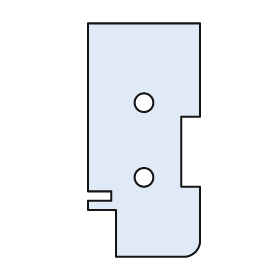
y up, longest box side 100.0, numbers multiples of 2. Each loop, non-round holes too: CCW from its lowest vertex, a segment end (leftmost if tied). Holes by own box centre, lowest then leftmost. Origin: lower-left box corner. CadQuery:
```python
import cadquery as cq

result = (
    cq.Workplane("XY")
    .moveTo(12.0, 0.0)
    .lineTo(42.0, 0.0)
    .threePointArc((46.0, 2.0), (48.0, 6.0))
    .lineTo(48.0, 30.0)
    .lineTo(40.0, 30.0)
    .lineTo(40.0, 60.0)
    .lineTo(48.0, 60.0)
    .lineTo(48.0, 100.0)
    .lineTo(0.0, 100.0)
    .lineTo(0.0, 28.0)
    .lineTo(10.0, 28.0)
    .lineTo(10.0, 24.0)
    .lineTo(0.0, 24.0)
    .lineTo(0.0, 20.0)
    .lineTo(12.0, 20.0)
    .close()
    .moveTo(24.0, 34.0)
    .circle(4.0)
    .moveTo(24.0, 66.0)
    .circle(4.0)
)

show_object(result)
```